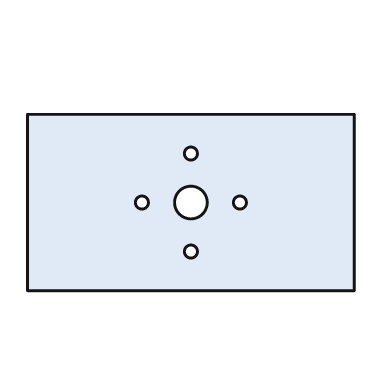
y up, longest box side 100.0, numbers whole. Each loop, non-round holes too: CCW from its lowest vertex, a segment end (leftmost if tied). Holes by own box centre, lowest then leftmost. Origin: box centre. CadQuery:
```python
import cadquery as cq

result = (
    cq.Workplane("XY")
    .moveTo(-50.0, -27.0)
    .lineTo(50.0, -27.0)
    .lineTo(50.0, 27.0)
    .lineTo(-50.0, 27.0)
    .close()
    .moveTo(0.0, -15.0)
    .circle(2.0)
    .moveTo(-15.0, 0.0)
    .circle(2.0)
    .moveTo(0.0, 0.0)
    .circle(5.0)
    .moveTo(15.0, 0.0)
    .circle(2.0)
    .moveTo(0.0, 15.0)
    .circle(2.0)
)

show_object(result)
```